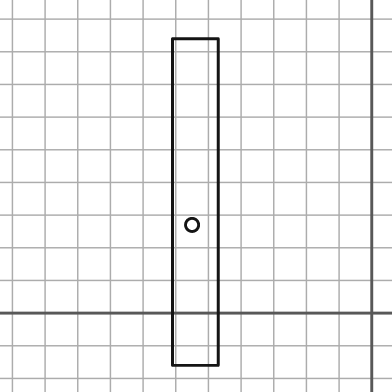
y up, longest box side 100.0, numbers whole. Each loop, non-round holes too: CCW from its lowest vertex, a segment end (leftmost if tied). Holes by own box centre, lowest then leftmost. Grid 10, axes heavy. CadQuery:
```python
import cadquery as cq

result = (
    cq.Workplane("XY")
    .moveTo(-61.0, -16.0)
    .lineTo(-47.0, -16.0)
    .lineTo(-47.0, 84.0)
    .lineTo(-61.0, 84.0)
    .close()
    .moveTo(-55.0, 27.0)
    .circle(2.0)
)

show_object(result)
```